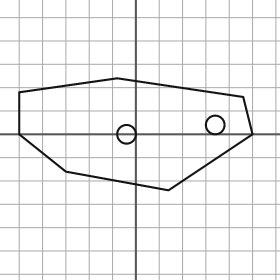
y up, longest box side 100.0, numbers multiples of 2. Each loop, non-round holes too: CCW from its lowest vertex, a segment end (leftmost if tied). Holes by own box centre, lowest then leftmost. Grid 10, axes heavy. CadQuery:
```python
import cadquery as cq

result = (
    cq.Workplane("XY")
    .moveTo(14.0, -24.0)
    .lineTo(50.0, 0.0)
    .lineTo(46.0, 16.0)
    .lineTo(-8.0, 24.0)
    .lineTo(-50.0, 18.0)
    .lineTo(-50.0, 0.0)
    .lineTo(-30.0, -16.0)
    .close()
    .moveTo(-4.0, 0.0)
    .circle(4.0)
    .moveTo(34.0, 4.0)
    .circle(4.0)
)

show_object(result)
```